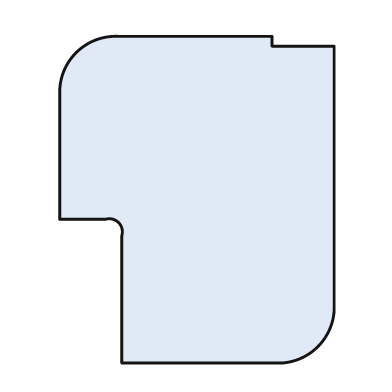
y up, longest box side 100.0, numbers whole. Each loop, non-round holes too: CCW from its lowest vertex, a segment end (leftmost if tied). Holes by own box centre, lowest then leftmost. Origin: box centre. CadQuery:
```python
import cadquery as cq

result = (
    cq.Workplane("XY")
    .moveTo(-23.0, -50.0)
    .lineTo(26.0, -50.0)
    .threePointArc((37.0, -45.0), (42.0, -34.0))
    .lineTo(42.0, 47.0)
    .lineTo(23.0, 47.0)
    .lineTo(23.0, 50.0)
    .lineTo(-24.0, 50.0)
    .threePointArc((-37.0, 45.0), (-42.0, 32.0))
    .lineTo(-42.0, -6.0)
    .lineTo(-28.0, -6.0)
    .threePointArc((-24.0, -7.0), (-23.0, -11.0))
    .close()
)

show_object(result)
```